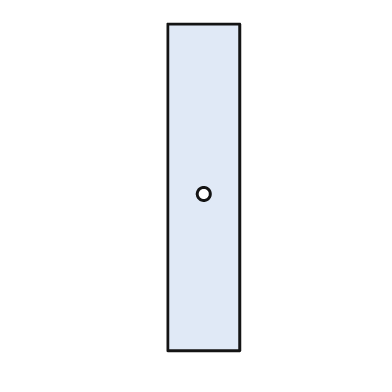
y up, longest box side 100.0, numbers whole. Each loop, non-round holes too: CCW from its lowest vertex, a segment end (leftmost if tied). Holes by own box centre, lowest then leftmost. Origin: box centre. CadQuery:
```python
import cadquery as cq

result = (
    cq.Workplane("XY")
    .moveTo(-11.0, -50.0)
    .lineTo(11.0, -50.0)
    .lineTo(11.0, 50.0)
    .lineTo(-11.0, 50.0)
    .close()
    .moveTo(0.0, -2.0)
    .circle(2.0)
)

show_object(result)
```